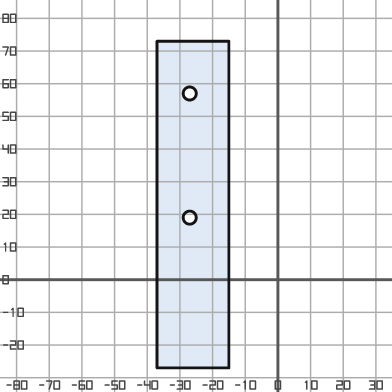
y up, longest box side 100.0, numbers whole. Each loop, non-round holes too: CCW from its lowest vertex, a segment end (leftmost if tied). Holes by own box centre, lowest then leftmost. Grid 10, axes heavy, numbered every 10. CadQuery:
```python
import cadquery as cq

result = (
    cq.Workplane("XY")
    .moveTo(-37.0, -27.0)
    .lineTo(-15.0, -27.0)
    .lineTo(-15.0, 73.0)
    .lineTo(-37.0, 73.0)
    .close()
    .moveTo(-27.0, 19.0)
    .circle(2.0)
    .moveTo(-27.0, 57.0)
    .circle(2.0)
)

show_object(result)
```